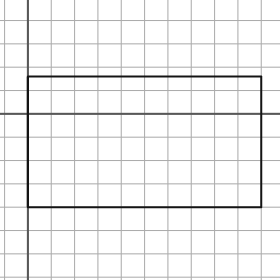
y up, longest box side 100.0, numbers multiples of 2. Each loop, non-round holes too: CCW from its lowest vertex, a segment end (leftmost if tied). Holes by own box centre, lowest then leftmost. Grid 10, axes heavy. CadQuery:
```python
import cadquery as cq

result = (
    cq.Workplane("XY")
    .moveTo(0.0, -40.0)
    .lineTo(100.0, -40.0)
    .lineTo(100.0, 16.0)
    .lineTo(0.0, 16.0)
    .close()
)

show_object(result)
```